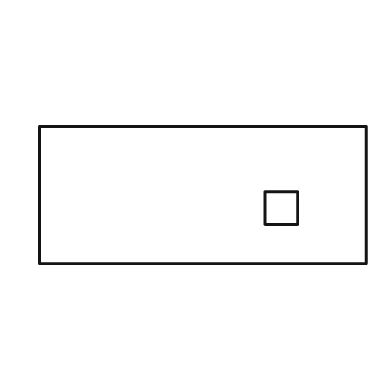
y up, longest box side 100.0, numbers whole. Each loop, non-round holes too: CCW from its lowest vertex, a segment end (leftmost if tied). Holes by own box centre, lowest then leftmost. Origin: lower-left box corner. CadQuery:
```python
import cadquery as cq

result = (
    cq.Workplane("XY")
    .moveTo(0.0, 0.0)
    .lineTo(100.0, 0.0)
    .lineTo(100.0, 42.0)
    .lineTo(0.0, 42.0)
    .close()
    .moveTo(69.0, 12.0)
    .lineTo(79.0, 12.0)
    .lineTo(79.0, 22.0)
    .lineTo(69.0, 22.0)
    .close()
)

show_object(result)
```